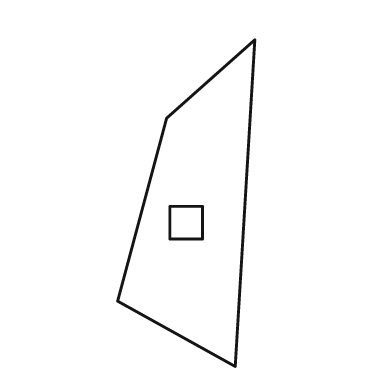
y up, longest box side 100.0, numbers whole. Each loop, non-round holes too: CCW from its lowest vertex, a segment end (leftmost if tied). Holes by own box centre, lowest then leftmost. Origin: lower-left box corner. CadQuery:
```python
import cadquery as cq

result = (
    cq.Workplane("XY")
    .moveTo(36.0, 0.0)
    .lineTo(42.0, 100.0)
    .lineTo(15.0, 76.0)
    .lineTo(0.0, 20.0)
    .close()
    .moveTo(16.0, 39.0)
    .lineTo(26.0, 39.0)
    .lineTo(26.0, 49.0)
    .lineTo(16.0, 49.0)
    .close()
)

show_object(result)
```